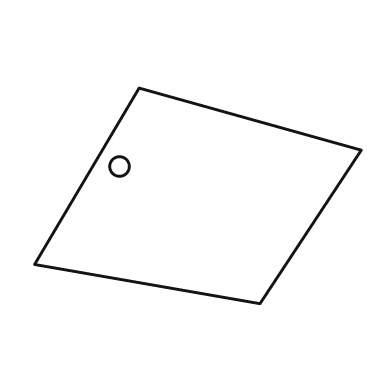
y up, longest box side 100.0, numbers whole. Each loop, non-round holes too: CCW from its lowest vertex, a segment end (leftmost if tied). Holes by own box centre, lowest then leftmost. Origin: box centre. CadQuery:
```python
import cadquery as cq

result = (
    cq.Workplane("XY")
    .moveTo(19.0, -33.0)
    .lineTo(50.0, 14.0)
    .lineTo(-18.0, 33.0)
    .lineTo(-50.0, -21.0)
    .close()
    .moveTo(-24.0, 9.0)
    .circle(3.0)
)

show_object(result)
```